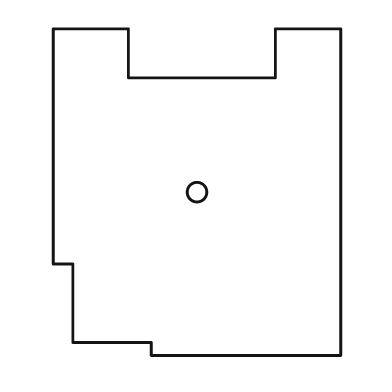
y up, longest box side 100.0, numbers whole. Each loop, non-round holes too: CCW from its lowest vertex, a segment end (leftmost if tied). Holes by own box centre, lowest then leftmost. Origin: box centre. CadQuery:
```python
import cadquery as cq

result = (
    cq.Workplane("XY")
    .moveTo(-14.0, -50.0)
    .lineTo(44.0, -50.0)
    .lineTo(44.0, 50.0)
    .lineTo(24.0, 50.0)
    .lineTo(24.0, 35.0)
    .lineTo(-21.0, 35.0)
    .lineTo(-21.0, 50.0)
    .lineTo(-44.0, 50.0)
    .lineTo(-44.0, -22.0)
    .lineTo(-38.0, -22.0)
    .lineTo(-38.0, -46.0)
    .lineTo(-14.0, -46.0)
    .close()
    .moveTo(0.0, 0.0)
    .circle(3.0)
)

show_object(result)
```